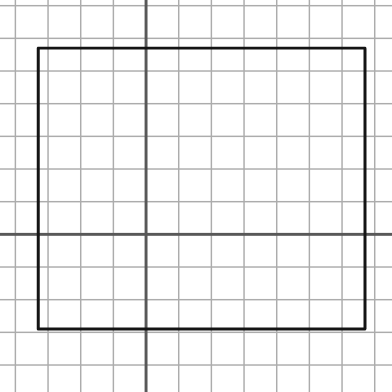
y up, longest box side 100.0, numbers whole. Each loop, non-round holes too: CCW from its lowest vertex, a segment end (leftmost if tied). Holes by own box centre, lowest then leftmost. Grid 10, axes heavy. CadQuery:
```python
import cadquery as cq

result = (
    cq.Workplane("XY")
    .moveTo(-33.0, -29.0)
    .lineTo(67.0, -29.0)
    .lineTo(67.0, 57.0)
    .lineTo(-33.0, 57.0)
    .close()
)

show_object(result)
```